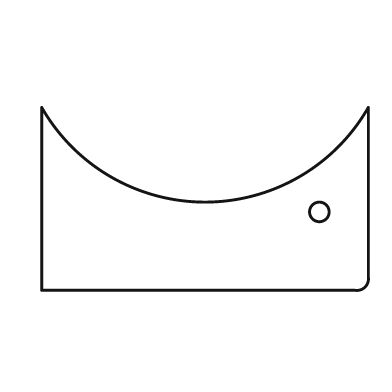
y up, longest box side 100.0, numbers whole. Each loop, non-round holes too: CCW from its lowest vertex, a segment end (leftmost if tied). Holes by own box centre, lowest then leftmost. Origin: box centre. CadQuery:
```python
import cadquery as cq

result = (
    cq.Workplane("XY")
    .moveTo(-50.0, -28.0)
    .lineTo(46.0, -28.0)
    .threePointArc((49.0, -27.0), (50.0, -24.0))
    .lineTo(50.0, 28.0)
    .threePointArc((0.0, -1.0), (-50.0, 28.0))
    .close()
    .moveTo(35.0, -4.0)
    .circle(3.0)
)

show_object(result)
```